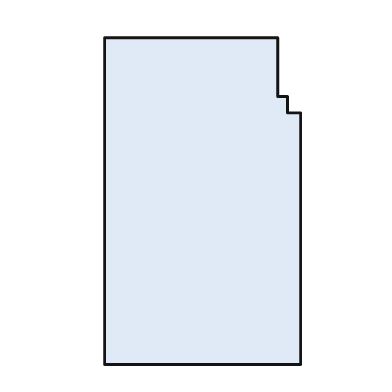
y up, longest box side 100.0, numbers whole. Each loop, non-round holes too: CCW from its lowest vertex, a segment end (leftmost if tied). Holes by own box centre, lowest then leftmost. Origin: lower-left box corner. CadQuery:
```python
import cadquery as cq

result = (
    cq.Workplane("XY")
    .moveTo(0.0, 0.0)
    .lineTo(60.0, 0.0)
    .lineTo(60.0, 77.0)
    .lineTo(56.0, 77.0)
    .lineTo(56.0, 82.0)
    .lineTo(53.0, 82.0)
    .lineTo(53.0, 100.0)
    .lineTo(0.0, 100.0)
    .close()
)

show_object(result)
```